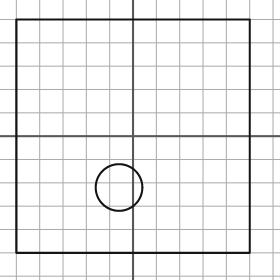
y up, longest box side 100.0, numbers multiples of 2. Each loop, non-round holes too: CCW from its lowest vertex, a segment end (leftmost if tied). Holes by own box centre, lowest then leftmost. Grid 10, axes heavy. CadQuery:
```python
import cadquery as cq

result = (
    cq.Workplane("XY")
    .moveTo(-50.0, -50.0)
    .lineTo(50.0, -50.0)
    .lineTo(50.0, 50.0)
    .lineTo(-50.0, 50.0)
    .close()
    .moveTo(-6.0, -22.0)
    .circle(10.0)
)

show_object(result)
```